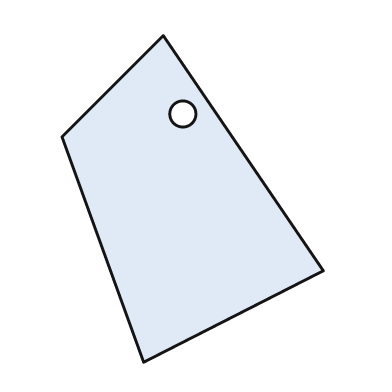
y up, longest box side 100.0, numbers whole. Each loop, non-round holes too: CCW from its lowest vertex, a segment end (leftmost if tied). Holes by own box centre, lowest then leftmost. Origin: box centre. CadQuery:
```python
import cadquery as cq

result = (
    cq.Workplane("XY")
    .moveTo(-15.0, -50.0)
    .lineTo(40.0, -22.0)
    .lineTo(-9.0, 50.0)
    .lineTo(-40.0, 19.0)
    .close()
    .moveTo(-3.0, 26.0)
    .circle(4.0)
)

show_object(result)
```